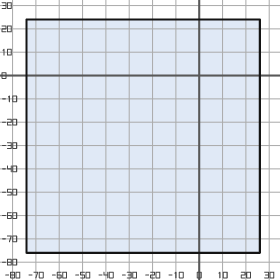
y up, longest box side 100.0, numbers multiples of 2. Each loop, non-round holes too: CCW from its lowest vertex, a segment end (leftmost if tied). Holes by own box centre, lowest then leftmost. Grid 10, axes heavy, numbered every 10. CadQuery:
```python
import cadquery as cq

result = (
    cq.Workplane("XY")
    .moveTo(-74.0, -76.0)
    .lineTo(26.0, -76.0)
    .lineTo(26.0, 24.0)
    .lineTo(-74.0, 24.0)
    .close()
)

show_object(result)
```